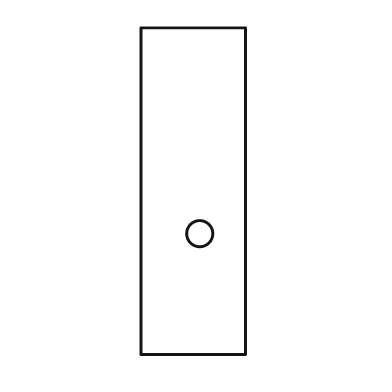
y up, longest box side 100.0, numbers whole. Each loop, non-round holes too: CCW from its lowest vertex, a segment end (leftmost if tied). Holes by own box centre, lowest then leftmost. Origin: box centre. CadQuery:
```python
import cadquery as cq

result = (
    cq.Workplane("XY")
    .moveTo(-16.0, -50.0)
    .lineTo(16.0, -50.0)
    .lineTo(16.0, 50.0)
    .lineTo(-16.0, 50.0)
    .close()
    .moveTo(2.0, -13.0)
    .circle(4.0)
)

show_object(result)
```